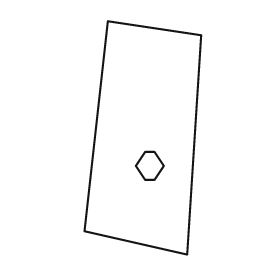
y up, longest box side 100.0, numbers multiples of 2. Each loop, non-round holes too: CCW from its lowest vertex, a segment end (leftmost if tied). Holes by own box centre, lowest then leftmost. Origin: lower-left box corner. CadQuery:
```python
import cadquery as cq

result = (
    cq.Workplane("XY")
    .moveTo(44.0, 0.0)
    .lineTo(50.0, 94.0)
    .lineTo(10.0, 100.0)
    .lineTo(0.0, 10.0)
    .close()
    .moveTo(26.0, 32.0)
    .lineTo(30.0, 32.0)
    .lineTo(34.0, 38.0)
    .lineTo(30.0, 44.0)
    .lineTo(26.0, 44.0)
    .lineTo(22.0, 38.0)
    .close()
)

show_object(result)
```